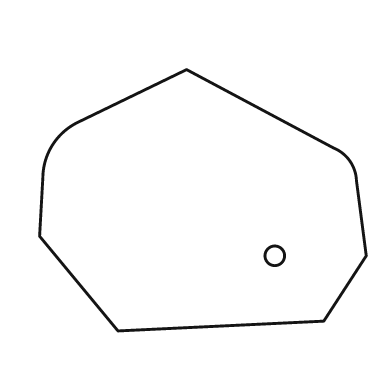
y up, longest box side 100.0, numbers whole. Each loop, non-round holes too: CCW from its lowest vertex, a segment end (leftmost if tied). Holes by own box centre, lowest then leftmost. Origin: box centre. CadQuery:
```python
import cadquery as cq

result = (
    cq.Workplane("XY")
    .moveTo(-26.0, -40.0)
    .lineTo(37.0, -37.0)
    .lineTo(50.0, -17.0)
    .lineTo(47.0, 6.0)
    .threePointArc((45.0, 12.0), (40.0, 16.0))
    .lineTo(-5.0, 40.0)
    .lineTo(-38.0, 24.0)
    .threePointArc((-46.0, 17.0), (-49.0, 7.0))
    .lineTo(-50.0, -11.0)
    .close()
    .moveTo(22.0, -17.0)
    .circle(3.0)
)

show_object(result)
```